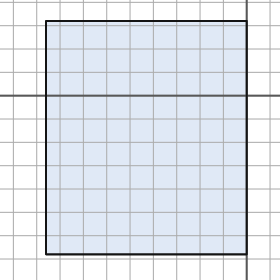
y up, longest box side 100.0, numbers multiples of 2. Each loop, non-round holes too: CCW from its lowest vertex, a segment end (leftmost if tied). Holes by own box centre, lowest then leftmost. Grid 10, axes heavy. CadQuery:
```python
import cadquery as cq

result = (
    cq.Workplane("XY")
    .moveTo(-86.0, -68.0)
    .lineTo(0.0, -68.0)
    .lineTo(0.0, 32.0)
    .lineTo(-86.0, 32.0)
    .close()
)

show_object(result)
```